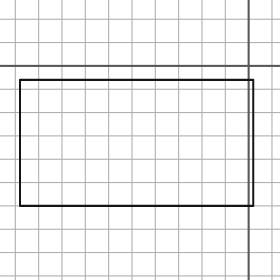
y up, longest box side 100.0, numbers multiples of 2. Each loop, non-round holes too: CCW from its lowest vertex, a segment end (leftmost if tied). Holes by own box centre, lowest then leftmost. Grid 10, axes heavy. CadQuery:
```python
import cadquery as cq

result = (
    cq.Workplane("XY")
    .moveTo(-98.0, -60.0)
    .lineTo(2.0, -60.0)
    .lineTo(2.0, -6.0)
    .lineTo(-98.0, -6.0)
    .close()
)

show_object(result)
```